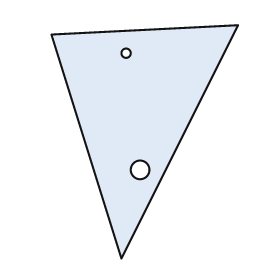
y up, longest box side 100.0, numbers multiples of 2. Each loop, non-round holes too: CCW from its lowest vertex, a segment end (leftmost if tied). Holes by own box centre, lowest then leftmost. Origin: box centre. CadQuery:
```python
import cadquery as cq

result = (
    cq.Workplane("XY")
    .moveTo(-10.0, -50.0)
    .lineTo(40.0, 50.0)
    .lineTo(-40.0, 46.0)
    .close()
    .moveTo(-2.0, -12.0)
    .circle(4.0)
    .moveTo(-8.0, 38.0)
    .circle(2.0)
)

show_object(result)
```